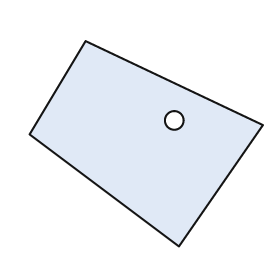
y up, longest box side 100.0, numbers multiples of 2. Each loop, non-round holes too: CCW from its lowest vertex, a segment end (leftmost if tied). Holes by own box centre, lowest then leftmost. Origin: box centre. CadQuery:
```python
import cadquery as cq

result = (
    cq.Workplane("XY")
    .moveTo(14.0, -44.0)
    .lineTo(50.0, 8.0)
    .lineTo(-26.0, 44.0)
    .lineTo(-50.0, 4.0)
    .close()
    .moveTo(12.0, 10.0)
    .circle(4.0)
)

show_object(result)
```